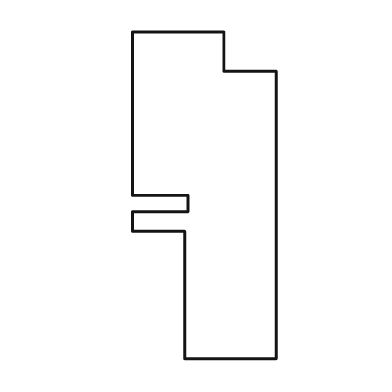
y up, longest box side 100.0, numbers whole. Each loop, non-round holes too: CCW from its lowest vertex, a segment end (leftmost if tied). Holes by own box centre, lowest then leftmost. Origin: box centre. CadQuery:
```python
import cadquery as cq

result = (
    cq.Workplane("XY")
    .moveTo(-6.0, -50.0)
    .lineTo(22.0, -50.0)
    .lineTo(22.0, 38.0)
    .lineTo(6.0, 38.0)
    .lineTo(6.0, 50.0)
    .lineTo(-22.0, 50.0)
    .lineTo(-22.0, 0.0)
    .lineTo(-5.0, 0.0)
    .lineTo(-5.0, -5.0)
    .lineTo(-22.0, -5.0)
    .lineTo(-22.0, -11.0)
    .lineTo(-6.0, -11.0)
    .close()
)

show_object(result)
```